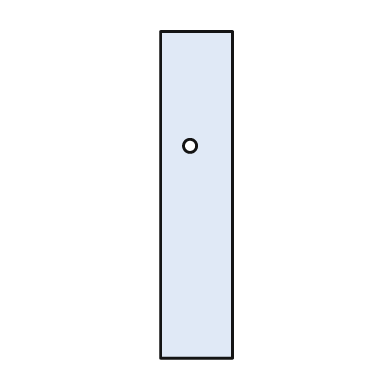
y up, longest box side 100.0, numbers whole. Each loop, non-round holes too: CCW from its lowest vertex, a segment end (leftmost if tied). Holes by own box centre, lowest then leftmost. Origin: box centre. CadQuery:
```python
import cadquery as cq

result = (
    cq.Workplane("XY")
    .moveTo(-11.0, -50.0)
    .lineTo(11.0, -50.0)
    .lineTo(11.0, 50.0)
    .lineTo(-11.0, 50.0)
    .close()
    .moveTo(-2.0, 15.0)
    .circle(2.0)
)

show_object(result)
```